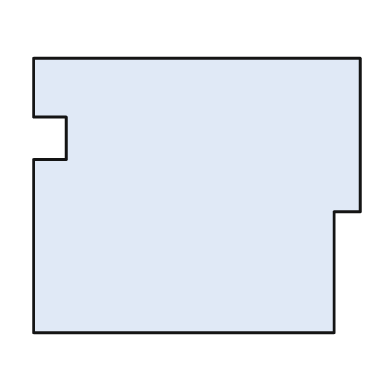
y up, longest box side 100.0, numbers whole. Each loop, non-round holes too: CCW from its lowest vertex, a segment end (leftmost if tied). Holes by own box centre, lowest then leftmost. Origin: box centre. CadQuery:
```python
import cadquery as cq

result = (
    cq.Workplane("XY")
    .moveTo(-50.0, -42.0)
    .lineTo(42.0, -42.0)
    .lineTo(42.0, -5.0)
    .lineTo(50.0, -5.0)
    .lineTo(50.0, 42.0)
    .lineTo(-50.0, 42.0)
    .lineTo(-50.0, 24.0)
    .lineTo(-40.0, 24.0)
    .lineTo(-40.0, 11.0)
    .lineTo(-50.0, 11.0)
    .close()
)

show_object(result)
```